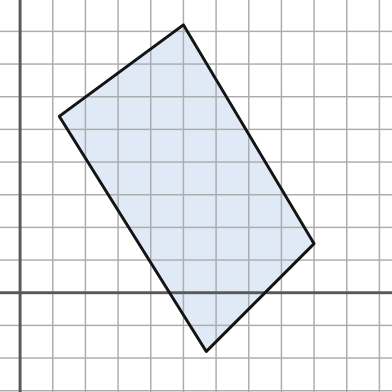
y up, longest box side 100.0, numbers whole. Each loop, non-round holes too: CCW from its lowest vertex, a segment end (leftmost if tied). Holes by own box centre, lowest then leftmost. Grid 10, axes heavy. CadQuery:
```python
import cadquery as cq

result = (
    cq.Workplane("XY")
    .moveTo(57.0, -18.0)
    .lineTo(90.0, 15.0)
    .lineTo(50.0, 82.0)
    .lineTo(12.0, 54.0)
    .close()
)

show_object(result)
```